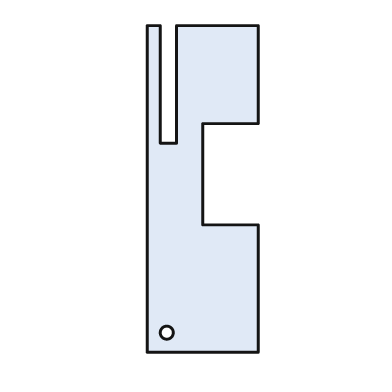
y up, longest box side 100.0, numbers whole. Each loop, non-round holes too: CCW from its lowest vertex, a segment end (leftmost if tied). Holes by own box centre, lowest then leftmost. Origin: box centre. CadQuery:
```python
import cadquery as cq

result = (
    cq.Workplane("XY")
    .moveTo(-17.0, -50.0)
    .lineTo(17.0, -50.0)
    .lineTo(17.0, -11.0)
    .lineTo(0.0, -11.0)
    .lineTo(0.0, 20.0)
    .lineTo(17.0, 20.0)
    .lineTo(17.0, 50.0)
    .lineTo(-8.0, 50.0)
    .lineTo(-8.0, 14.0)
    .lineTo(-13.0, 14.0)
    .lineTo(-13.0, 50.0)
    .lineTo(-17.0, 50.0)
    .close()
    .moveTo(-11.0, -44.0)
    .circle(2.0)
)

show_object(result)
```